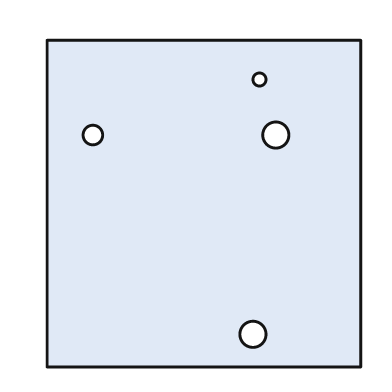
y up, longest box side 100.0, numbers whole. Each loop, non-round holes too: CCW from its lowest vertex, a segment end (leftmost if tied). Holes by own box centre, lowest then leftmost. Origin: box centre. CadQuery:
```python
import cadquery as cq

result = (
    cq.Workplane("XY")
    .moveTo(-48.0, -50.0)
    .lineTo(48.0, -50.0)
    .lineTo(48.0, 50.0)
    .lineTo(-48.0, 50.0)
    .close()
    .moveTo(15.0, -40.0)
    .circle(4.0)
    .moveTo(-34.0, 21.0)
    .circle(3.0)
    .moveTo(22.0, 21.0)
    .circle(4.0)
    .moveTo(17.0, 38.0)
    .circle(2.0)
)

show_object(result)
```